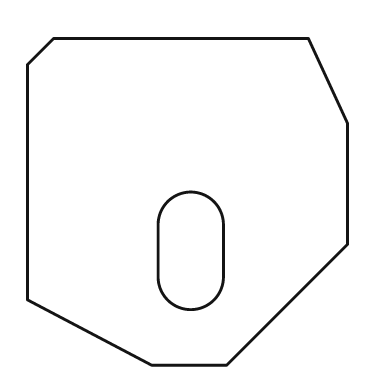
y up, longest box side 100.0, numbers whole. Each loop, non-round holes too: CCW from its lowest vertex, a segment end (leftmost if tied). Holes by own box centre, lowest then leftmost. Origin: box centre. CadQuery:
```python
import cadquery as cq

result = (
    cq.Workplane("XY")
    .moveTo(-11.0, -50.0)
    .lineTo(12.0, -50.0)
    .lineTo(49.0, -13.0)
    .lineTo(49.0, 24.0)
    .lineTo(37.0, 50.0)
    .lineTo(-41.0, 50.0)
    .lineTo(-49.0, 42.0)
    .lineTo(-49.0, -30.0)
    .close()
    .moveTo(-9.0, -23.0)
    .threePointArc((1.0, -33.0), (11.0, -23.0))
    .lineTo(11.0, -7.0)
    .threePointArc((1.0, 3.0), (-9.0, -7.0))
    .close()
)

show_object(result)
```